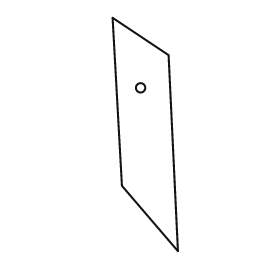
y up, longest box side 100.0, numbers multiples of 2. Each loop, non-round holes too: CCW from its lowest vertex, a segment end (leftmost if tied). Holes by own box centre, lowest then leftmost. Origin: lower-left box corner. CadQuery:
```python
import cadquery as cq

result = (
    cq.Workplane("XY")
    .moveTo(28.0, 0.0)
    .lineTo(24.0, 84.0)
    .lineTo(0.0, 100.0)
    .lineTo(4.0, 28.0)
    .close()
    .moveTo(12.0, 70.0)
    .circle(2.0)
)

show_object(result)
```